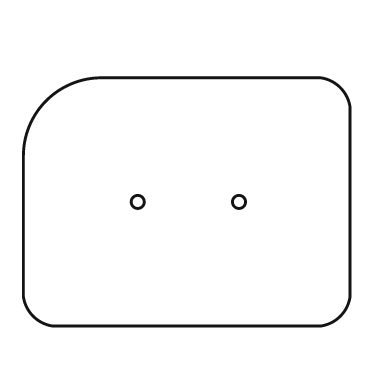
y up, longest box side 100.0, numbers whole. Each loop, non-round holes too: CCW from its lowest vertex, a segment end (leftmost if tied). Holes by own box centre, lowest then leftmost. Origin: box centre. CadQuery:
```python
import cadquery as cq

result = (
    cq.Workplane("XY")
    .moveTo(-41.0, -38.0)
    .lineTo(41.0, -38.0)
    .threePointArc((47.0, -35.0), (50.0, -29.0))
    .lineTo(50.0, 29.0)
    .threePointArc((47.0, 35.0), (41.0, 38.0))
    .lineTo(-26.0, 38.0)
    .threePointArc((-43.0, 31.0), (-50.0, 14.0))
    .lineTo(-50.0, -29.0)
    .threePointArc((-47.0, -35.0), (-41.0, -38.0))
    .close()
    .moveTo(-15.0, 0.0)
    .circle(2.0)
    .moveTo(16.0, 0.0)
    .circle(2.0)
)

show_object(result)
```